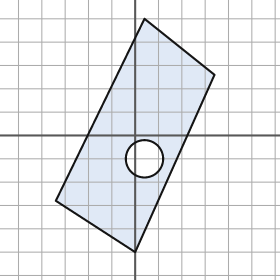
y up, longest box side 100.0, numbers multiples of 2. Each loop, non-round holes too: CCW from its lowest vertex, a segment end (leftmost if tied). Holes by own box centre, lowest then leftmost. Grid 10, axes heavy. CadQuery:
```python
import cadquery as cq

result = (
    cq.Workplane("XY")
    .moveTo(0.0, -50.0)
    .lineTo(34.0, 26.0)
    .lineTo(4.0, 50.0)
    .lineTo(-34.0, -28.0)
    .close()
    .moveTo(4.0, -10.0)
    .circle(8.0)
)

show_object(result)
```